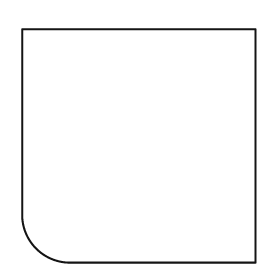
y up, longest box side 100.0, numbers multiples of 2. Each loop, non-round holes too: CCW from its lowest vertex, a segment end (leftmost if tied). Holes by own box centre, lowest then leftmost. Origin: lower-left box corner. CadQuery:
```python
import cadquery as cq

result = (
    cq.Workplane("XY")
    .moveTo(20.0, 0.0)
    .lineTo(100.0, 0.0)
    .lineTo(100.0, 100.0)
    .lineTo(0.0, 100.0)
    .lineTo(0.0, 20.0)
    .threePointArc((6.0, 6.0), (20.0, 0.0))
    .close()
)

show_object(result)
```